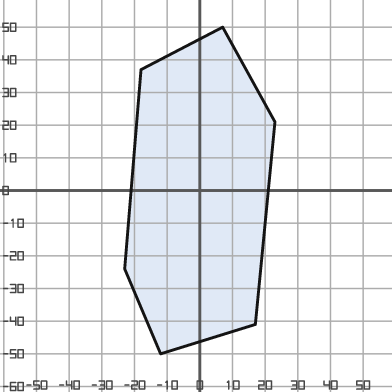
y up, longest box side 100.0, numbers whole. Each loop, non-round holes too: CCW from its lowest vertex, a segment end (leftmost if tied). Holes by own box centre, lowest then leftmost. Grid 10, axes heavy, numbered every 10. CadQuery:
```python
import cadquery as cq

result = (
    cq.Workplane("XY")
    .moveTo(-12.0, -50.0)
    .lineTo(17.0, -41.0)
    .lineTo(23.0, 21.0)
    .lineTo(7.0, 50.0)
    .lineTo(-18.0, 37.0)
    .lineTo(-23.0, -24.0)
    .close()
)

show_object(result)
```